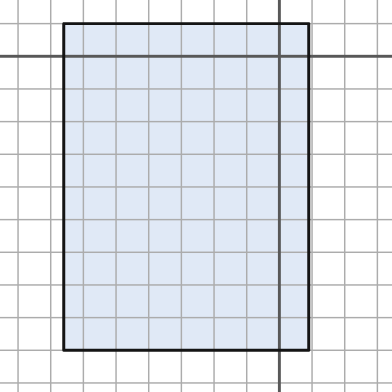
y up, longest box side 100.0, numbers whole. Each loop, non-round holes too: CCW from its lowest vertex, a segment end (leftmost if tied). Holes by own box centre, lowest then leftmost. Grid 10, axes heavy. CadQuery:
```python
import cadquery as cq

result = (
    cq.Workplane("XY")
    .moveTo(-66.0, -90.0)
    .lineTo(9.0, -90.0)
    .lineTo(9.0, 10.0)
    .lineTo(-66.0, 10.0)
    .close()
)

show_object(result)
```